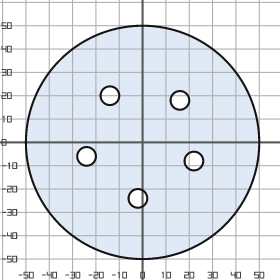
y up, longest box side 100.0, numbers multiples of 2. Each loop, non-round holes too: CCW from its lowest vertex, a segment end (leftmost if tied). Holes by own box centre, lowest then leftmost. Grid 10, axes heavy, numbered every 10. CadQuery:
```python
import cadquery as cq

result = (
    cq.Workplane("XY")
    .moveTo(0.0, 0.0)
    .circle(50.0)
    .moveTo(-2.0, -24.0)
    .circle(4.0)
    .moveTo(22.0, -8.0)
    .circle(4.0)
    .moveTo(-24.0, -6.0)
    .circle(4.0)
    .moveTo(16.0, 18.0)
    .circle(4.0)
    .moveTo(-14.0, 20.0)
    .circle(4.0)
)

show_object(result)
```